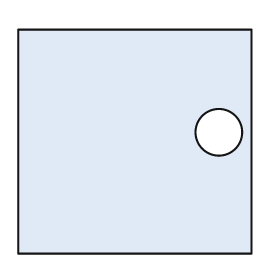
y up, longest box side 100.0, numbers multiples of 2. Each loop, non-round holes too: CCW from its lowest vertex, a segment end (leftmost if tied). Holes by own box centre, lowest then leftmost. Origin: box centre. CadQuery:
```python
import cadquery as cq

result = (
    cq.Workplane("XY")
    .moveTo(-50.0, -48.0)
    .lineTo(50.0, -48.0)
    .lineTo(50.0, 48.0)
    .lineTo(-50.0, 48.0)
    .close()
    .moveTo(36.0, 4.0)
    .circle(10.0)
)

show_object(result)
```